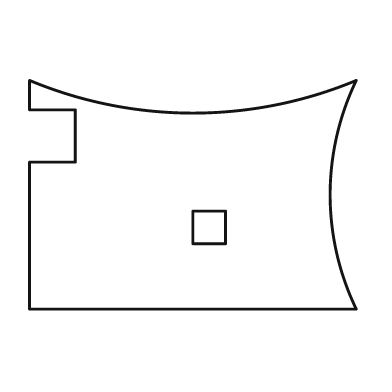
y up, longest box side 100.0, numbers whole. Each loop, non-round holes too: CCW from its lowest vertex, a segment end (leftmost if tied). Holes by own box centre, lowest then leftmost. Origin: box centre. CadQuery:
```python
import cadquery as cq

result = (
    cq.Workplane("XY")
    .moveTo(-50.0, -35.0)
    .lineTo(50.0, -35.0)
    .threePointArc((42.0, 0.0), (50.0, 35.0))
    .threePointArc((0.0, 25.0), (-50.0, 35.0))
    .lineTo(-50.0, 26.0)
    .lineTo(-36.0, 26.0)
    .lineTo(-36.0, 10.0)
    .lineTo(-50.0, 10.0)
    .close()
    .moveTo(0.0, -15.0)
    .lineTo(10.0, -15.0)
    .lineTo(10.0, -5.0)
    .lineTo(0.0, -5.0)
    .close()
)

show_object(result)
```